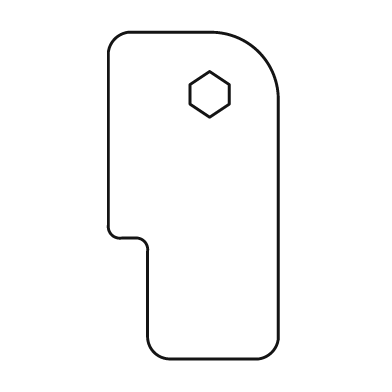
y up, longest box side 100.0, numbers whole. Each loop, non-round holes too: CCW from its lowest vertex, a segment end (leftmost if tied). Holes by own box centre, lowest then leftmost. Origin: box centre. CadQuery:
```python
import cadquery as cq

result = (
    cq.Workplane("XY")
    .moveTo(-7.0, -50.0)
    .lineTo(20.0, -50.0)
    .threePointArc((24.0, -48.0), (26.0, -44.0))
    .lineTo(26.0, 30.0)
    .threePointArc((20.0, 44.0), (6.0, 50.0))
    .lineTo(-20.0, 50.0)
    .threePointArc((-24.0, 48.0), (-26.0, 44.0))
    .lineTo(-26.0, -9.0)
    .threePointArc((-25.0, -12.0), (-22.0, -13.0))
    .lineTo(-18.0, -13.0)
    .threePointArc((-15.0, -14.0), (-14.0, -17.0))
    .lineTo(-14.0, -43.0)
    .threePointArc((-12.0, -48.0), (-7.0, -50.0))
    .close()
    .moveTo(5.0, 24.0)
    .lineTo(11.0, 28.0)
    .lineTo(11.0, 34.0)
    .lineTo(5.0, 38.0)
    .lineTo(-1.0, 34.0)
    .lineTo(-1.0, 28.0)
    .close()
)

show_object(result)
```